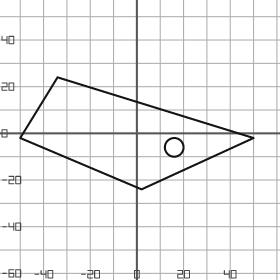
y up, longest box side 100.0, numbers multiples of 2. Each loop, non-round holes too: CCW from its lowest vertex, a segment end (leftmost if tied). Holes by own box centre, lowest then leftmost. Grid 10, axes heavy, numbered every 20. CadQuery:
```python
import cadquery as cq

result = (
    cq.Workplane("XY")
    .moveTo(2.0, -24.0)
    .lineTo(50.0, -2.0)
    .lineTo(-34.0, 24.0)
    .lineTo(-50.0, -2.0)
    .close()
    .moveTo(16.0, -6.0)
    .circle(4.0)
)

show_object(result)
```